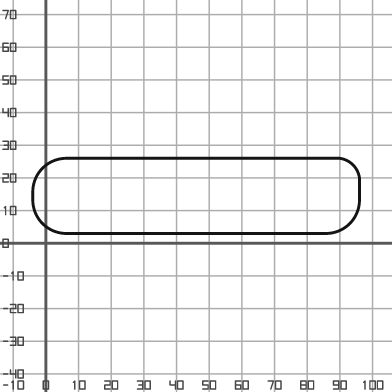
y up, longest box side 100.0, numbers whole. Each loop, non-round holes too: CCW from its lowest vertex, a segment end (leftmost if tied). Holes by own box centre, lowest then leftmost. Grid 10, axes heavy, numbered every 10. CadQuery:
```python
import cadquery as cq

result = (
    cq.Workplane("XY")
    .moveTo(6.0, 3.0)
    .lineTo(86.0, 3.0)
    .threePointArc((93.0, 6.0), (96.0, 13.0))
    .lineTo(96.0, 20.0)
    .threePointArc((94.0, 24.0), (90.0, 26.0))
    .lineTo(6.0, 26.0)
    .threePointArc((-1.0, 23.0), (-4.0, 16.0))
    .lineTo(-4.0, 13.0)
    .threePointArc((-1.0, 6.0), (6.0, 3.0))
    .close()
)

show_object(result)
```